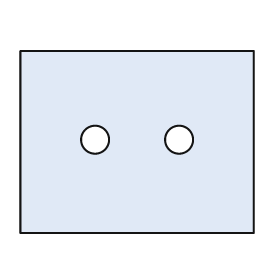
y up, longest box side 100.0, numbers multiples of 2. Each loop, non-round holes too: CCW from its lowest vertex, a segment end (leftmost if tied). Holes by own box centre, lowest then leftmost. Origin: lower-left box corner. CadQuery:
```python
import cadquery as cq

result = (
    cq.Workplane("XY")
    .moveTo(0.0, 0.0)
    .lineTo(100.0, 0.0)
    .lineTo(100.0, 78.0)
    .lineTo(0.0, 78.0)
    .close()
    .moveTo(32.0, 40.0)
    .circle(6.0)
    .moveTo(68.0, 40.0)
    .circle(6.0)
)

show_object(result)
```